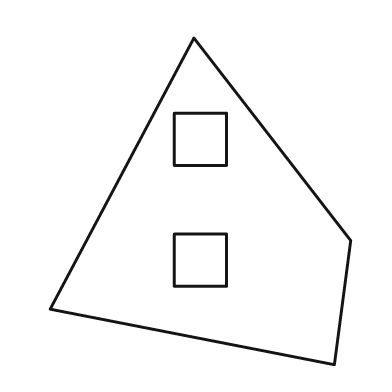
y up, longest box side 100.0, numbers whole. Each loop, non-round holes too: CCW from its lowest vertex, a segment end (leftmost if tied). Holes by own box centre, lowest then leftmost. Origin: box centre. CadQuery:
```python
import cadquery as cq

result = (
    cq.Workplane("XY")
    .moveTo(41.0, -50.0)
    .lineTo(46.0, -12.0)
    .lineTo(-2.0, 50.0)
    .lineTo(-46.0, -33.0)
    .close()
    .moveTo(-8.0, -26.0)
    .lineTo(8.0, -26.0)
    .lineTo(8.0, -10.0)
    .lineTo(-8.0, -10.0)
    .close()
    .moveTo(-8.0, 11.0)
    .lineTo(8.0, 11.0)
    .lineTo(8.0, 27.0)
    .lineTo(-8.0, 27.0)
    .close()
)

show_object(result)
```